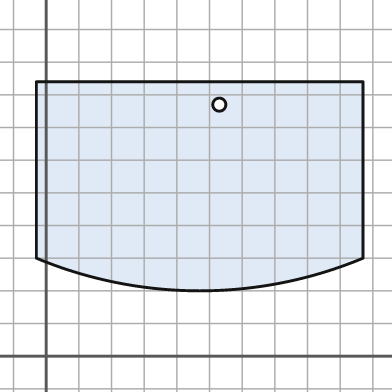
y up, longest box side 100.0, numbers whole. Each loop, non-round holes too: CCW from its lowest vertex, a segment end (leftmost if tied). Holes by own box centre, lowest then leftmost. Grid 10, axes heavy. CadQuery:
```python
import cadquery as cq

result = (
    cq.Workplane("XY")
    .moveTo(-3.0, 30.0)
    .threePointArc((47.0, 20.0), (97.0, 30.0))
    .lineTo(97.0, 84.0)
    .lineTo(-3.0, 84.0)
    .close()
    .moveTo(53.0, 77.0)
    .circle(2.0)
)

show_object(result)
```